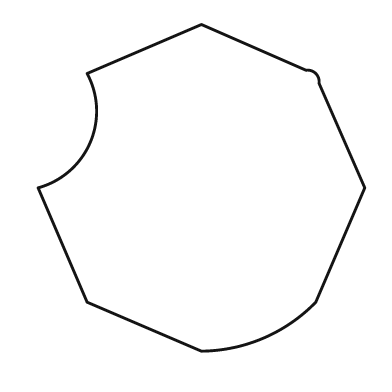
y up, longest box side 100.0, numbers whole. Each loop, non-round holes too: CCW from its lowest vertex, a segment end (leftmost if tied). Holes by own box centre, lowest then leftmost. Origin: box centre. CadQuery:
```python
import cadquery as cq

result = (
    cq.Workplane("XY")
    .moveTo(0.0, -50.0)
    .threePointArc((19.0, -46.0), (35.0, -35.0))
    .lineTo(50.0, 0.0)
    .lineTo(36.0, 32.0)
    .threePointArc((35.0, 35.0), (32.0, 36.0))
    .lineTo(0.0, 50.0)
    .lineTo(-35.0, 35.0)
    .threePointArc((-34.0, 14.0), (-50.0, 0.0))
    .lineTo(-35.0, -35.0)
    .close()
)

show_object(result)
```